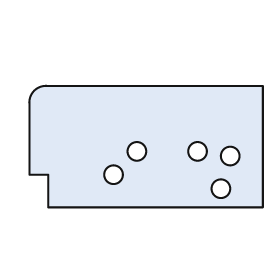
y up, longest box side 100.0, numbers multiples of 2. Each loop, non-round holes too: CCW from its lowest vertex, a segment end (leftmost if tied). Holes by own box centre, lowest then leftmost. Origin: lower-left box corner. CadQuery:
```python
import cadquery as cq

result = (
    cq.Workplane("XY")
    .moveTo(8.0, 0.0)
    .lineTo(100.0, 0.0)
    .lineTo(100.0, 52.0)
    .lineTo(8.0, 52.0)
    .threePointArc((2.0, 50.0), (0.0, 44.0))
    .lineTo(0.0, 14.0)
    .lineTo(8.0, 14.0)
    .close()
    .moveTo(82.0, 8.0)
    .circle(4.0)
    .moveTo(36.0, 14.0)
    .circle(4.0)
    .moveTo(86.0, 22.0)
    .circle(4.0)
    .moveTo(46.0, 24.0)
    .circle(4.0)
    .moveTo(72.0, 24.0)
    .circle(4.0)
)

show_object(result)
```